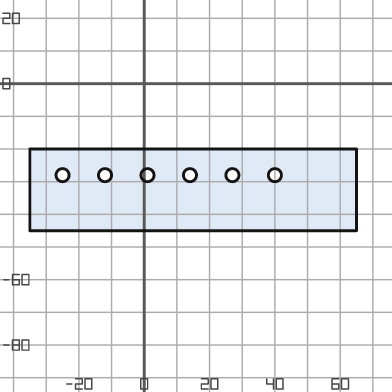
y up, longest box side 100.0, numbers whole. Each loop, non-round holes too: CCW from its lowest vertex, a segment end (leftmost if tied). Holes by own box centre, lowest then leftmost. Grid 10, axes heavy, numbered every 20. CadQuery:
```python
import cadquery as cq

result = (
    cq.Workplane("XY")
    .moveTo(-35.0, -45.0)
    .lineTo(65.0, -45.0)
    .lineTo(65.0, -20.0)
    .lineTo(-35.0, -20.0)
    .close()
    .moveTo(-25.0, -28.0)
    .circle(2.0)
    .moveTo(-12.0, -28.0)
    .circle(2.0)
    .moveTo(1.0, -28.0)
    .circle(2.0)
    .moveTo(14.0, -28.0)
    .circle(2.0)
    .moveTo(27.0, -28.0)
    .circle(2.0)
    .moveTo(40.0, -28.0)
    .circle(2.0)
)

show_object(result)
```